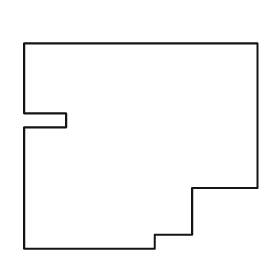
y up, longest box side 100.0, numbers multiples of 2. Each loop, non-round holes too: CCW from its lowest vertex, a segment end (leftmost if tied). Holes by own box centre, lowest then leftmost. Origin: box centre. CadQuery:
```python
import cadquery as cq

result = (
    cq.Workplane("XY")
    .moveTo(-50.0, -44.0)
    .lineTo(6.0, -44.0)
    .lineTo(6.0, -38.0)
    .lineTo(22.0, -38.0)
    .lineTo(22.0, -18.0)
    .lineTo(50.0, -18.0)
    .lineTo(50.0, 44.0)
    .lineTo(-50.0, 44.0)
    .lineTo(-50.0, 14.0)
    .lineTo(-32.0, 14.0)
    .lineTo(-32.0, 8.0)
    .lineTo(-50.0, 8.0)
    .close()
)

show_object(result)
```